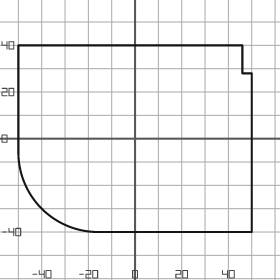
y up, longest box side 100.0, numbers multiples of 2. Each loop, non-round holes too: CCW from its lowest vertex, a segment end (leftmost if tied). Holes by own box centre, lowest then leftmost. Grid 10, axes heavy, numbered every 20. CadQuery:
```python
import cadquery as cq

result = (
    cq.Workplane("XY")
    .moveTo(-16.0, -40.0)
    .lineTo(50.0, -40.0)
    .lineTo(50.0, 28.0)
    .lineTo(46.0, 28.0)
    .lineTo(46.0, 40.0)
    .lineTo(-50.0, 40.0)
    .lineTo(-50.0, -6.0)
    .threePointArc((-40.0, -30.0), (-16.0, -40.0))
    .close()
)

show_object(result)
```